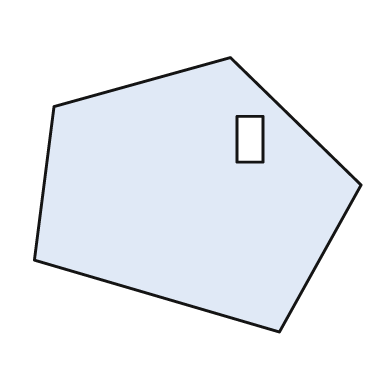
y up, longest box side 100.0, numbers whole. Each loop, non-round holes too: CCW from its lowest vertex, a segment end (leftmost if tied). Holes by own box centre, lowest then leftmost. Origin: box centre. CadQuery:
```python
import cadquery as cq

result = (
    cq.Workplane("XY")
    .moveTo(25.0, -42.0)
    .lineTo(50.0, 3.0)
    .lineTo(10.0, 42.0)
    .lineTo(-44.0, 27.0)
    .lineTo(-50.0, -20.0)
    .close()
    .moveTo(12.0, 10.0)
    .lineTo(20.0, 10.0)
    .lineTo(20.0, 24.0)
    .lineTo(12.0, 24.0)
    .close()
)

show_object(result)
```